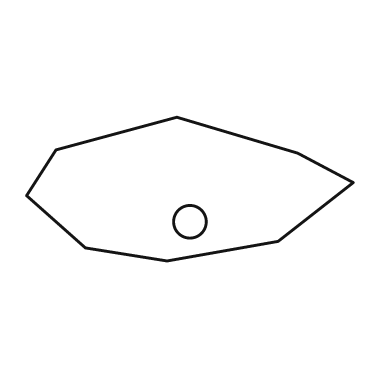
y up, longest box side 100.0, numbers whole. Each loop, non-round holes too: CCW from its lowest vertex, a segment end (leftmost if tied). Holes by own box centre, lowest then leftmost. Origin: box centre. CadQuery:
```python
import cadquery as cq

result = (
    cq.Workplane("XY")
    .moveTo(-7.0, -22.0)
    .lineTo(27.0, -16.0)
    .lineTo(50.0, 2.0)
    .lineTo(33.0, 11.0)
    .lineTo(-4.0, 22.0)
    .lineTo(-41.0, 12.0)
    .lineTo(-50.0, -2.0)
    .lineTo(-32.0, -18.0)
    .close()
    .moveTo(0.0, -10.0)
    .circle(5.0)
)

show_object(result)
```